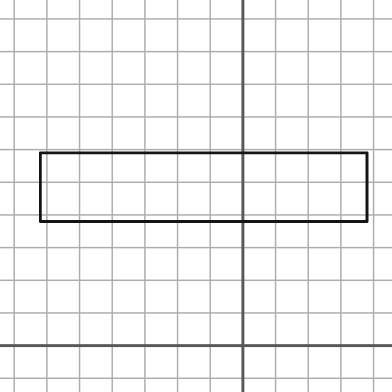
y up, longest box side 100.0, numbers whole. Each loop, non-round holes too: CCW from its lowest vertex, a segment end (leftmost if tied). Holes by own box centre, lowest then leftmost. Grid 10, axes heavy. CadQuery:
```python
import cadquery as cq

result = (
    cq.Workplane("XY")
    .moveTo(-62.0, 38.0)
    .lineTo(38.0, 38.0)
    .lineTo(38.0, 59.0)
    .lineTo(-62.0, 59.0)
    .close()
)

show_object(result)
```